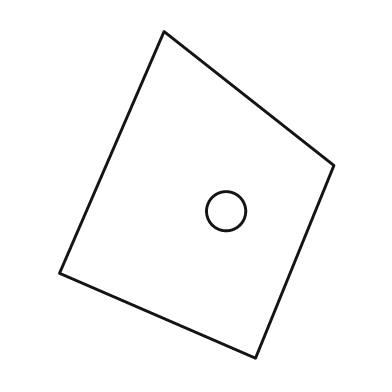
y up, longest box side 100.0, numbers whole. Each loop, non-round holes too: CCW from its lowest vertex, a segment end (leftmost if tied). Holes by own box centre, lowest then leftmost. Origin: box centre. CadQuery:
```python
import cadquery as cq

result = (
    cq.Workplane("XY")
    .moveTo(18.0, -50.0)
    .lineTo(42.0, 9.0)
    .lineTo(-10.0, 50.0)
    .lineTo(-42.0, -24.0)
    .close()
    .moveTo(9.0, -5.0)
    .circle(6.0)
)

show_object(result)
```